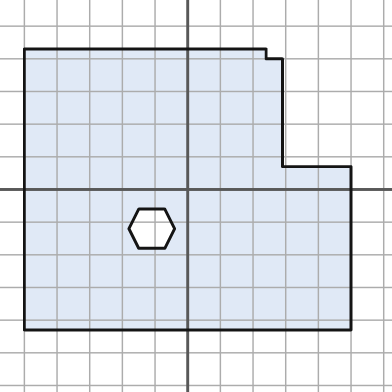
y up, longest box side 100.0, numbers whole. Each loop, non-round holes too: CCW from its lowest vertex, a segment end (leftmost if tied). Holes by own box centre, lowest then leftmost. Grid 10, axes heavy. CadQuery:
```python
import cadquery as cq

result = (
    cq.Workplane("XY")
    .moveTo(-50.0, -43.0)
    .lineTo(50.0, -43.0)
    .lineTo(50.0, 7.0)
    .lineTo(29.0, 7.0)
    .lineTo(29.0, 40.0)
    .lineTo(24.0, 40.0)
    .lineTo(24.0, 43.0)
    .lineTo(-50.0, 43.0)
    .close()
    .moveTo(-15.0, -18.0)
    .lineTo(-7.0, -18.0)
    .lineTo(-4.0, -12.0)
    .lineTo(-7.0, -6.0)
    .lineTo(-15.0, -6.0)
    .lineTo(-18.0, -12.0)
    .close()
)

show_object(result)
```